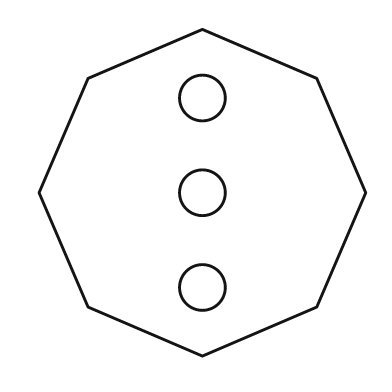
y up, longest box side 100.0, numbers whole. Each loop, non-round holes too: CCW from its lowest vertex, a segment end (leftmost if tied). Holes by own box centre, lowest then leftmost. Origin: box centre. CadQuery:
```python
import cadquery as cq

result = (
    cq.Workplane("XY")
    .moveTo(0.0, -50.0)
    .lineTo(35.0, -35.0)
    .lineTo(50.0, 0.0)
    .lineTo(35.0, 35.0)
    .lineTo(0.0, 50.0)
    .lineTo(-35.0, 35.0)
    .lineTo(-50.0, 0.0)
    .lineTo(-35.0, -35.0)
    .close()
    .moveTo(0.0, -29.0)
    .circle(7.0)
    .moveTo(0.0, 0.0)
    .circle(7.0)
    .moveTo(0.0, 29.0)
    .circle(7.0)
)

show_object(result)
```